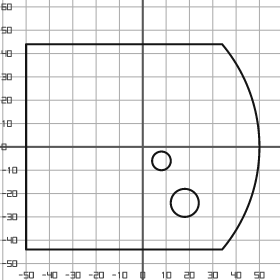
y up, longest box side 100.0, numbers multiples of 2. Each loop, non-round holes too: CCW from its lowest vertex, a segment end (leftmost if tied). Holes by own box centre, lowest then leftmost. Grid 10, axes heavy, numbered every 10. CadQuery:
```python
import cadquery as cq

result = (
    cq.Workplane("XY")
    .moveTo(-50.0, -44.0)
    .lineTo(34.0, -44.0)
    .threePointArc((50.0, 0.0), (34.0, 44.0))
    .lineTo(-50.0, 44.0)
    .close()
    .moveTo(18.0, -24.0)
    .circle(6.0)
    .moveTo(8.0, -6.0)
    .circle(4.0)
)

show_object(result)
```